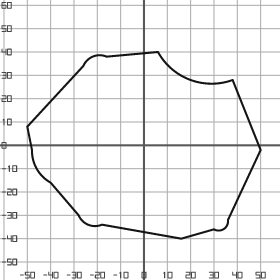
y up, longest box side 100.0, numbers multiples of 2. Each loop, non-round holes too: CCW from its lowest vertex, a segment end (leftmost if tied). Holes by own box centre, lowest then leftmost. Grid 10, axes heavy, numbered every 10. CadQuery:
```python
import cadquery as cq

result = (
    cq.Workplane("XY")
    .moveTo(16.0, -40.0)
    .lineTo(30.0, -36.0)
    .threePointArc((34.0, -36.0), (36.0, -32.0))
    .lineTo(50.0, -2.0)
    .lineTo(38.0, 28.0)
    .threePointArc((20.0, 28.0), (6.0, 40.0))
    .lineTo(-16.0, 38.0)
    .threePointArc((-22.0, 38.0), (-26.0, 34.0))
    .lineTo(-50.0, 8.0)
    .lineTo(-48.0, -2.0)
    .threePointArc((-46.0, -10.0), (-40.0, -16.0))
    .lineTo(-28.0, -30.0)
    .threePointArc((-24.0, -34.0), (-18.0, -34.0))
    .close()
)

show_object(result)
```